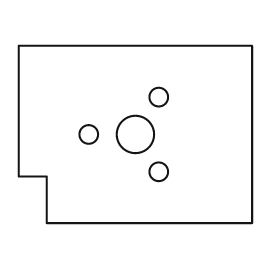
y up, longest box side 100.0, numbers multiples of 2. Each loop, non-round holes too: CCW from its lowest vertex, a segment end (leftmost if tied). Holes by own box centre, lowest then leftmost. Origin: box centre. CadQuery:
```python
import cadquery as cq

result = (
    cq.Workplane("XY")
    .moveTo(-38.0, -38.0)
    .lineTo(50.0, -38.0)
    .lineTo(50.0, 38.0)
    .lineTo(-50.0, 38.0)
    .lineTo(-50.0, -18.0)
    .lineTo(-38.0, -18.0)
    .close()
    .moveTo(10.0, -16.0)
    .circle(4.0)
    .moveTo(-20.0, 0.0)
    .circle(4.0)
    .moveTo(0.0, 0.0)
    .circle(8.0)
    .moveTo(10.0, 16.0)
    .circle(4.0)
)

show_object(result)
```